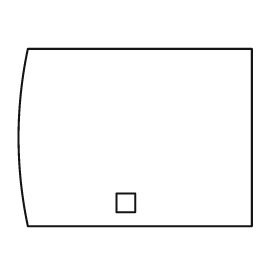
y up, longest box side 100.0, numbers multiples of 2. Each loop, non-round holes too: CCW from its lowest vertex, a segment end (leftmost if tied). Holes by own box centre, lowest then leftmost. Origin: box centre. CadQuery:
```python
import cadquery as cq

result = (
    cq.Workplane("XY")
    .moveTo(-46.0, -38.0)
    .lineTo(50.0, -38.0)
    .lineTo(50.0, 38.0)
    .lineTo(-46.0, 38.0)
    .threePointArc((-50.0, 0.0), (-46.0, -38.0))
    .close()
    .moveTo(-8.0, -32.0)
    .lineTo(0.0, -32.0)
    .lineTo(0.0, -24.0)
    .lineTo(-8.0, -24.0)
    .close()
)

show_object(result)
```